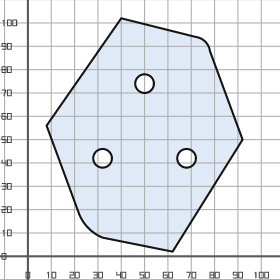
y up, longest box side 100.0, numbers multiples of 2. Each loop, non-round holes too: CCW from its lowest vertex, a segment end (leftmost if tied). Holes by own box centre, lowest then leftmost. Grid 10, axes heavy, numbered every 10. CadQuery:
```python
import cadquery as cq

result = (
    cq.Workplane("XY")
    .moveTo(62.0, 2.0)
    .lineTo(92.0, 50.0)
    .lineTo(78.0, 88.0)
    .threePointArc((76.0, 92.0), (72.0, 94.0))
    .lineTo(40.0, 102.0)
    .lineTo(8.0, 56.0)
    .lineTo(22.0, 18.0)
    .threePointArc((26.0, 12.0), (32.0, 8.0))
    .close()
    .moveTo(32.0, 42.0)
    .circle(4.0)
    .moveTo(68.0, 42.0)
    .circle(4.0)
    .moveTo(50.0, 74.0)
    .circle(4.0)
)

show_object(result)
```